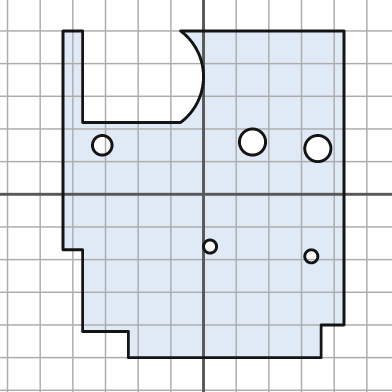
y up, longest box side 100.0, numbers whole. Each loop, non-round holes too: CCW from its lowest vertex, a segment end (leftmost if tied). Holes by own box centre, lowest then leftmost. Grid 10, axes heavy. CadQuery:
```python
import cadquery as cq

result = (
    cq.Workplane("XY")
    .moveTo(-23.0, -50.0)
    .lineTo(36.0, -50.0)
    .lineTo(36.0, -40.0)
    .lineTo(43.0, -40.0)
    .lineTo(43.0, 50.0)
    .lineTo(-7.0, 50.0)
    .threePointArc((0.0, 36.0), (-7.0, 22.0))
    .lineTo(-37.0, 22.0)
    .lineTo(-37.0, 50.0)
    .lineTo(-43.0, 50.0)
    .lineTo(-43.0, -17.0)
    .lineTo(-37.0, -17.0)
    .lineTo(-37.0, -42.0)
    .lineTo(-23.0, -42.0)
    .close()
    .moveTo(33.0, -19.0)
    .circle(2.0)
    .moveTo(2.0, -16.0)
    .circle(2.0)
    .moveTo(35.0, 14.0)
    .circle(4.0)
    .moveTo(-31.0, 15.0)
    .circle(3.0)
    .moveTo(15.0, 16.0)
    .circle(4.0)
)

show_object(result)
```